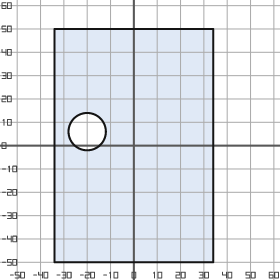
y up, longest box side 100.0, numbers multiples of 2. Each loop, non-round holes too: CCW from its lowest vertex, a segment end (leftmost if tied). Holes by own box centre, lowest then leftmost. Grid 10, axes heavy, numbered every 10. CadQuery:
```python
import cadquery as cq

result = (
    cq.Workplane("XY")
    .moveTo(-34.0, -50.0)
    .lineTo(34.0, -50.0)
    .lineTo(34.0, 50.0)
    .lineTo(-34.0, 50.0)
    .close()
    .moveTo(-20.0, 6.0)
    .circle(8.0)
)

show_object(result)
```